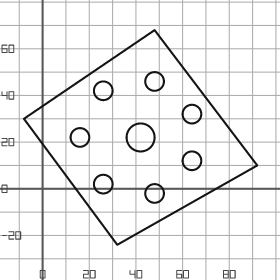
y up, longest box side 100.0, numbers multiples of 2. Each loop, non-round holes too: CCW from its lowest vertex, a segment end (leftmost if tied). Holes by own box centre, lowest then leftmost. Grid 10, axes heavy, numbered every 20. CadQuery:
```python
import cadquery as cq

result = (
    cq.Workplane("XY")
    .moveTo(32.0, -24.0)
    .lineTo(92.0, 10.0)
    .lineTo(48.0, 68.0)
    .lineTo(-8.0, 30.0)
    .close()
    .moveTo(48.0, -2.0)
    .circle(4.0)
    .moveTo(26.0, 2.0)
    .circle(4.0)
    .moveTo(64.0, 12.0)
    .circle(4.0)
    .moveTo(16.0, 22.0)
    .circle(4.0)
    .moveTo(42.0, 22.0)
    .circle(6.0)
    .moveTo(64.0, 32.0)
    .circle(4.0)
    .moveTo(26.0, 42.0)
    .circle(4.0)
    .moveTo(48.0, 46.0)
    .circle(4.0)
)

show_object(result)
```